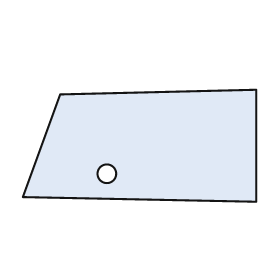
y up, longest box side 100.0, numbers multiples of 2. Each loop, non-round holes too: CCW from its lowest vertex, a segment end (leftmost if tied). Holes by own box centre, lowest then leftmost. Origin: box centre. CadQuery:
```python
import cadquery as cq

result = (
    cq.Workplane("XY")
    .moveTo(50.0, -24.0)
    .lineTo(50.0, 24.0)
    .lineTo(-34.0, 22.0)
    .lineTo(-50.0, -22.0)
    .close()
    .moveTo(-14.0, -12.0)
    .circle(4.0)
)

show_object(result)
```